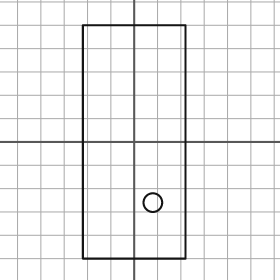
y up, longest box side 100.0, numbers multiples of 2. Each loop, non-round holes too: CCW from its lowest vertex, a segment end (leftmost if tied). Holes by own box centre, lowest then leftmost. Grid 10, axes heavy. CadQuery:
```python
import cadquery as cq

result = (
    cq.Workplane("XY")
    .moveTo(-22.0, -50.0)
    .lineTo(22.0, -50.0)
    .lineTo(22.0, 50.0)
    .lineTo(-22.0, 50.0)
    .close()
    .moveTo(8.0, -26.0)
    .circle(4.0)
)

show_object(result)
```